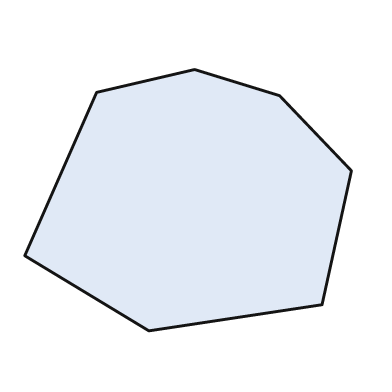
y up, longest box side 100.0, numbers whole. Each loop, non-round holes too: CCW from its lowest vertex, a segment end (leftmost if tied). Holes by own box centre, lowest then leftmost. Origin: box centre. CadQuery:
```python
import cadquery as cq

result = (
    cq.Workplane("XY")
    .moveTo(-12.0, -40.0)
    .lineTo(41.0, -32.0)
    .lineTo(50.0, 9.0)
    .lineTo(28.0, 32.0)
    .lineTo(2.0, 40.0)
    .lineTo(-28.0, 33.0)
    .lineTo(-50.0, -17.0)
    .close()
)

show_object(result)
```